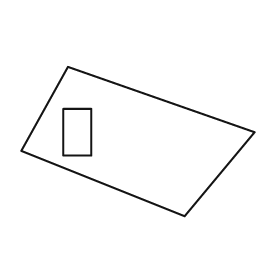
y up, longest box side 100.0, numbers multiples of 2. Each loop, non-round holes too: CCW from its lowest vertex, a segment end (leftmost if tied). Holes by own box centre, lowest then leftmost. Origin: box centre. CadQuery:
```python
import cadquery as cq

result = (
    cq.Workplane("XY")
    .moveTo(20.0, -32.0)
    .lineTo(50.0, 4.0)
    .lineTo(-30.0, 32.0)
    .lineTo(-50.0, -4.0)
    .close()
    .moveTo(-32.0, -6.0)
    .lineTo(-20.0, -6.0)
    .lineTo(-20.0, 14.0)
    .lineTo(-32.0, 14.0)
    .close()
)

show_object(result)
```